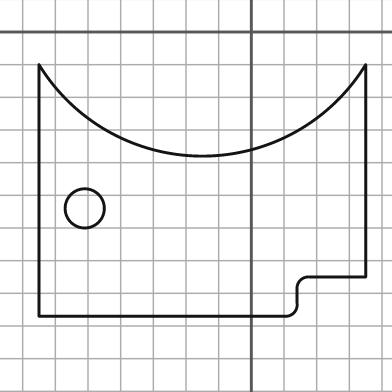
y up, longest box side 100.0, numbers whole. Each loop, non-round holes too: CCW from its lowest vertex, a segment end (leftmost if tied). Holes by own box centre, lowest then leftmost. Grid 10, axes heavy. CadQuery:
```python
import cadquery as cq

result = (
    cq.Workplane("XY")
    .moveTo(-65.0, -87.0)
    .lineTo(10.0, -87.0)
    .threePointArc((13.0, -86.0), (14.0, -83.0))
    .lineTo(14.0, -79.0)
    .threePointArc((15.0, -76.0), (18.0, -75.0))
    .lineTo(35.0, -75.0)
    .lineTo(35.0, -10.0)
    .threePointArc((-15.0, -38.0), (-65.0, -10.0))
    .close()
    .moveTo(-51.0, -54.0)
    .circle(6.0)
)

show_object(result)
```